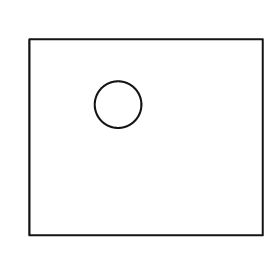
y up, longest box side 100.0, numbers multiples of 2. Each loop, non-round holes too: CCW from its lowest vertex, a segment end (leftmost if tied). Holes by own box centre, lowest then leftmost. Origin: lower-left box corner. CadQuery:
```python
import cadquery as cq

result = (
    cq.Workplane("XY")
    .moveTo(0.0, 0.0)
    .lineTo(100.0, 0.0)
    .lineTo(100.0, 84.0)
    .lineTo(0.0, 84.0)
    .close()
    .moveTo(38.0, 56.0)
    .circle(10.0)
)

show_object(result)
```